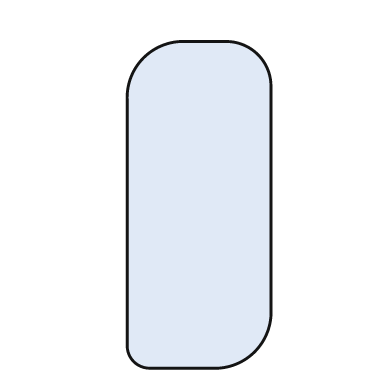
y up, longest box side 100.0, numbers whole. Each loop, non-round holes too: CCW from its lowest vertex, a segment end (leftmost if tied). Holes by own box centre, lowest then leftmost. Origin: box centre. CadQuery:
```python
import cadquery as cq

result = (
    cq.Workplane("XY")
    .moveTo(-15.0, -50.0)
    .lineTo(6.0, -50.0)
    .threePointArc((17.0, -45.0), (22.0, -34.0))
    .lineTo(22.0, 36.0)
    .threePointArc((18.0, 46.0), (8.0, 50.0))
    .lineTo(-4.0, 50.0)
    .threePointArc((-17.0, 45.0), (-22.0, 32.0))
    .lineTo(-22.0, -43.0)
    .threePointArc((-20.0, -48.0), (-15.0, -50.0))
    .close()
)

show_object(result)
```